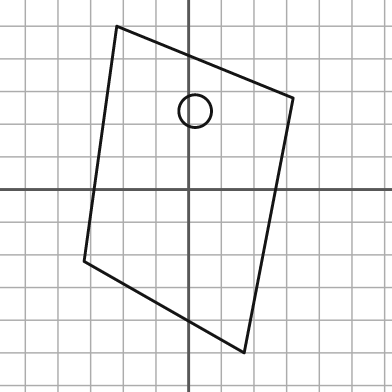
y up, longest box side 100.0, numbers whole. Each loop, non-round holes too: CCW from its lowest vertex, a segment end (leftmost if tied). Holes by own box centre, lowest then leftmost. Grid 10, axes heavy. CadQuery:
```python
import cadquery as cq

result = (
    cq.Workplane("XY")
    .moveTo(17.0, -50.0)
    .lineTo(32.0, 28.0)
    .lineTo(-22.0, 50.0)
    .lineTo(-32.0, -22.0)
    .close()
    .moveTo(2.0, 24.0)
    .circle(5.0)
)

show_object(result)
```